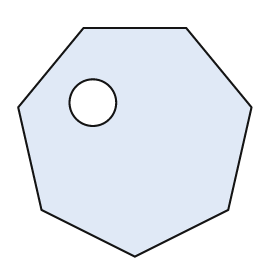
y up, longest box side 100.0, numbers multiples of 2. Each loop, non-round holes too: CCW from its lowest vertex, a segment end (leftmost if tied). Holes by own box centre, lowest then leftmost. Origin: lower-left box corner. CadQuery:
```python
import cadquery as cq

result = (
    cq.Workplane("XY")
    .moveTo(50.0, 0.0)
    .lineTo(90.0, 20.0)
    .lineTo(100.0, 64.0)
    .lineTo(72.0, 98.0)
    .lineTo(28.0, 98.0)
    .lineTo(0.0, 64.0)
    .lineTo(10.0, 20.0)
    .close()
    .moveTo(32.0, 66.0)
    .circle(10.0)
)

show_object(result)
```